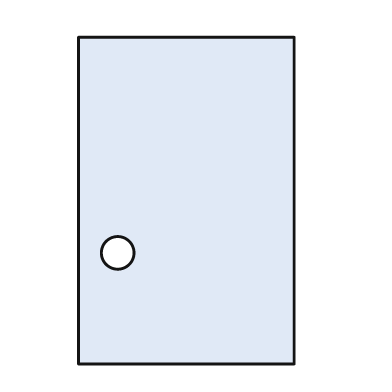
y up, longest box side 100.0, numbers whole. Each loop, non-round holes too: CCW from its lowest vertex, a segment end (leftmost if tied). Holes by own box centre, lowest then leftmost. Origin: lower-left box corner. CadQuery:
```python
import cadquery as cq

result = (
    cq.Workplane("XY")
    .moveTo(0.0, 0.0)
    .lineTo(66.0, 0.0)
    .lineTo(66.0, 100.0)
    .lineTo(0.0, 100.0)
    .close()
    .moveTo(12.0, 34.0)
    .circle(5.0)
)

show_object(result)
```